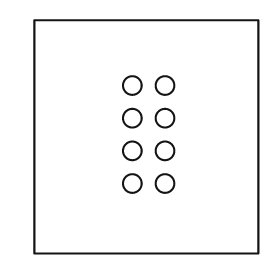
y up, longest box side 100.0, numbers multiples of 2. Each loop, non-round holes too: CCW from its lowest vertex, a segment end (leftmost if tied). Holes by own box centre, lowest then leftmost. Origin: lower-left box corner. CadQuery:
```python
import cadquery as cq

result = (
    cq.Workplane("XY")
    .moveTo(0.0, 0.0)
    .lineTo(96.0, 0.0)
    .lineTo(96.0, 100.0)
    .lineTo(0.0, 100.0)
    .close()
    .moveTo(42.0, 30.0)
    .circle(4.0)
    .moveTo(56.0, 30.0)
    .circle(4.0)
    .moveTo(42.0, 44.0)
    .circle(4.0)
    .moveTo(56.0, 44.0)
    .circle(4.0)
    .moveTo(42.0, 58.0)
    .circle(4.0)
    .moveTo(56.0, 58.0)
    .circle(4.0)
    .moveTo(42.0, 72.0)
    .circle(4.0)
    .moveTo(56.0, 72.0)
    .circle(4.0)
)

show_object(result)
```